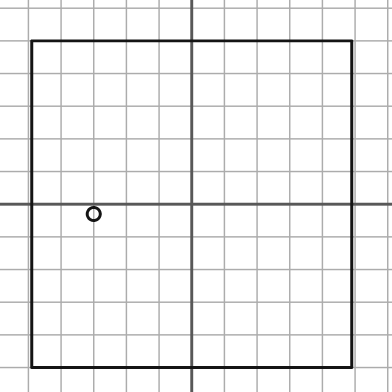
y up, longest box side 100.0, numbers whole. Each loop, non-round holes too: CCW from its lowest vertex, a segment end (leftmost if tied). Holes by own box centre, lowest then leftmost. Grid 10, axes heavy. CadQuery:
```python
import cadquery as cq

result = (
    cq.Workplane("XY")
    .moveTo(-49.0, -50.0)
    .lineTo(49.0, -50.0)
    .lineTo(49.0, 50.0)
    .lineTo(-49.0, 50.0)
    .close()
    .moveTo(-30.0, -3.0)
    .circle(2.0)
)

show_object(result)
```